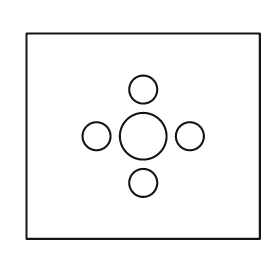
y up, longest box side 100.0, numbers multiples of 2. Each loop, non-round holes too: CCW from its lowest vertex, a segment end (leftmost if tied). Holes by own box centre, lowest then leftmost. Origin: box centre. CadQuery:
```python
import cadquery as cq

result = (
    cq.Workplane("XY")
    .moveTo(-50.0, -44.0)
    .lineTo(50.0, -44.0)
    .lineTo(50.0, 44.0)
    .lineTo(-50.0, 44.0)
    .close()
    .moveTo(0.0, -20.0)
    .circle(6.0)
    .moveTo(-20.0, 0.0)
    .circle(6.0)
    .moveTo(0.0, 0.0)
    .circle(10.0)
    .moveTo(20.0, 0.0)
    .circle(6.0)
    .moveTo(0.0, 20.0)
    .circle(6.0)
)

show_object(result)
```